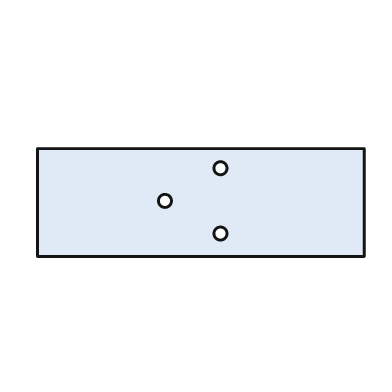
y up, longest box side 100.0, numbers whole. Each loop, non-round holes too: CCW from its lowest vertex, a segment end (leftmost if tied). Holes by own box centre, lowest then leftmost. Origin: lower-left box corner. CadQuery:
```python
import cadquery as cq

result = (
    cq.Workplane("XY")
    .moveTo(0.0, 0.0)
    .lineTo(100.0, 0.0)
    .lineTo(100.0, 33.0)
    .lineTo(0.0, 33.0)
    .close()
    .moveTo(56.0, 7.0)
    .circle(2.0)
    .moveTo(39.0, 17.0)
    .circle(2.0)
    .moveTo(56.0, 27.0)
    .circle(2.0)
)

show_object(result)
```